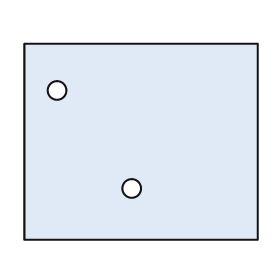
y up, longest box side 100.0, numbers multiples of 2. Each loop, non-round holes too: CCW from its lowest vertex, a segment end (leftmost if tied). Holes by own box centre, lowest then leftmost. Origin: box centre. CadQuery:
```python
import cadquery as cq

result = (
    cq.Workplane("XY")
    .moveTo(-50.0, -42.0)
    .lineTo(50.0, -42.0)
    .lineTo(50.0, 42.0)
    .lineTo(-50.0, 42.0)
    .close()
    .moveTo(-4.0, -20.0)
    .circle(4.0)
    .moveTo(-36.0, 22.0)
    .circle(4.0)
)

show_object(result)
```